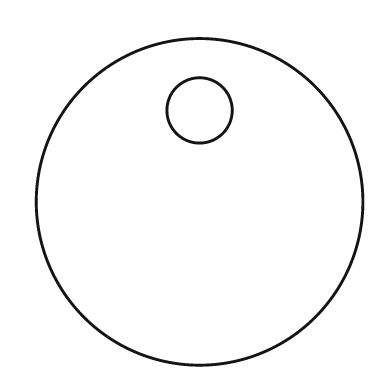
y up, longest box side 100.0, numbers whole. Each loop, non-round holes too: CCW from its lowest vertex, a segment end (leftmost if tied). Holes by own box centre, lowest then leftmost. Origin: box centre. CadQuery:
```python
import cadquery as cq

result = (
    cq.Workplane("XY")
    .moveTo(0.0, 0.0)
    .circle(50.0)
    .moveTo(0.0, 28.0)
    .circle(10.0)
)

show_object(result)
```